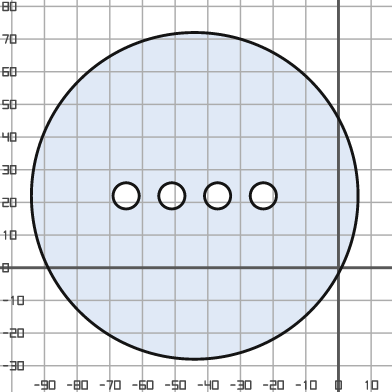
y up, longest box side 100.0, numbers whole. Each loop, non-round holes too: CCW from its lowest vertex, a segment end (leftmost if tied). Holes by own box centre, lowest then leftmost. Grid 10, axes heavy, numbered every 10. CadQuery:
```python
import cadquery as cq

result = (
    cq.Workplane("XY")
    .moveTo(-44.0, 22.0)
    .circle(50.0)
    .moveTo(-65.0, 22.0)
    .circle(4.0)
    .moveTo(-51.0, 22.0)
    .circle(4.0)
    .moveTo(-37.0, 22.0)
    .circle(4.0)
    .moveTo(-23.0, 22.0)
    .circle(4.0)
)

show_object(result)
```